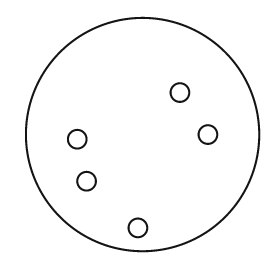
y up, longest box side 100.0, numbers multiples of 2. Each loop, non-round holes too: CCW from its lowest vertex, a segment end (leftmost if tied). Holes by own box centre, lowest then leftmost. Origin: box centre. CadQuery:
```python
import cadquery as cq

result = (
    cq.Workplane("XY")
    .moveTo(0.0, 0.0)
    .circle(50.0)
    .moveTo(-2.0, -40.0)
    .circle(4.0)
    .moveTo(-24.0, -20.0)
    .circle(4.0)
    .moveTo(-28.0, -2.0)
    .circle(4.0)
    .moveTo(28.0, 0.0)
    .circle(4.0)
    .moveTo(16.0, 18.0)
    .circle(4.0)
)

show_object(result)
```